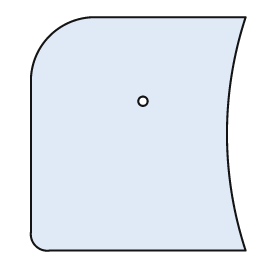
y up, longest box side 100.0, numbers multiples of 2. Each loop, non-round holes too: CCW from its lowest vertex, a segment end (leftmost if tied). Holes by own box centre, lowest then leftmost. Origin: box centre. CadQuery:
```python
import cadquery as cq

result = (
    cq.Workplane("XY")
    .moveTo(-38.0, -50.0)
    .lineTo(46.0, -50.0)
    .threePointArc((38.0, 0.0), (46.0, 50.0))
    .lineTo(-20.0, 50.0)
    .threePointArc((-38.0, 42.0), (-46.0, 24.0))
    .lineTo(-46.0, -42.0)
    .threePointArc((-44.0, -48.0), (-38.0, -50.0))
    .close()
    .moveTo(2.0, 14.0)
    .circle(2.0)
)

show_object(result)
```